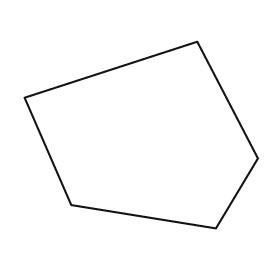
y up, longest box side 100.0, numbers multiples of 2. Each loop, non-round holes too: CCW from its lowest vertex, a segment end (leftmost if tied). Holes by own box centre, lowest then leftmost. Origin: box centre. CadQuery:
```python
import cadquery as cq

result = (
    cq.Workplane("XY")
    .moveTo(32.0, -40.0)
    .lineTo(50.0, -10.0)
    .lineTo(24.0, 40.0)
    .lineTo(-50.0, 16.0)
    .lineTo(-30.0, -30.0)
    .close()
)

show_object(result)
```